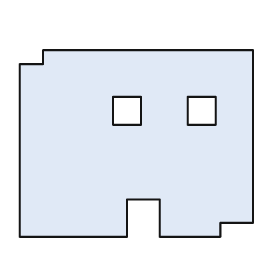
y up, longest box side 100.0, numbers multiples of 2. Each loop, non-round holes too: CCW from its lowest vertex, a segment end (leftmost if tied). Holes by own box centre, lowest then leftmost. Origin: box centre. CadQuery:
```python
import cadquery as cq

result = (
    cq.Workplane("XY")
    .moveTo(-50.0, -40.0)
    .lineTo(-4.0, -40.0)
    .lineTo(-4.0, -24.0)
    .lineTo(10.0, -24.0)
    .lineTo(10.0, -40.0)
    .lineTo(36.0, -40.0)
    .lineTo(36.0, -34.0)
    .lineTo(50.0, -34.0)
    .lineTo(50.0, 40.0)
    .lineTo(-40.0, 40.0)
    .lineTo(-40.0, 34.0)
    .lineTo(-50.0, 34.0)
    .close()
    .moveTo(-10.0, 8.0)
    .lineTo(2.0, 8.0)
    .lineTo(2.0, 20.0)
    .lineTo(-10.0, 20.0)
    .close()
    .moveTo(22.0, 8.0)
    .lineTo(34.0, 8.0)
    .lineTo(34.0, 20.0)
    .lineTo(22.0, 20.0)
    .close()
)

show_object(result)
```